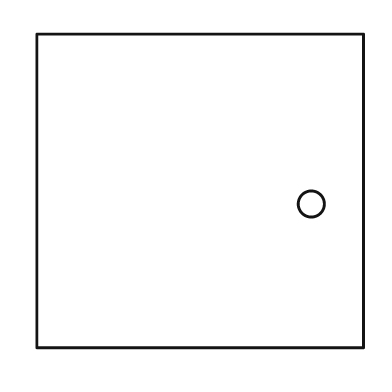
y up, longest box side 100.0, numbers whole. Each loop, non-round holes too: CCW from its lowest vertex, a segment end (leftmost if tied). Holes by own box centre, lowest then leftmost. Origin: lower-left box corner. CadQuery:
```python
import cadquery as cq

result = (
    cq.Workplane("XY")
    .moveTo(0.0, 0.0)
    .lineTo(100.0, 0.0)
    .lineTo(100.0, 96.0)
    .lineTo(0.0, 96.0)
    .close()
    .moveTo(84.0, 44.0)
    .circle(4.0)
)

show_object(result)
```